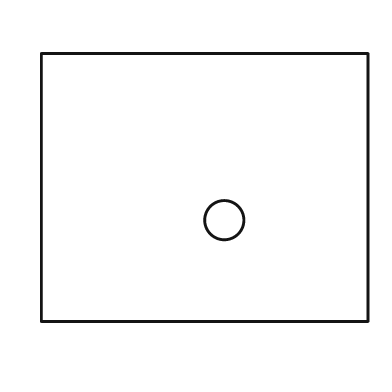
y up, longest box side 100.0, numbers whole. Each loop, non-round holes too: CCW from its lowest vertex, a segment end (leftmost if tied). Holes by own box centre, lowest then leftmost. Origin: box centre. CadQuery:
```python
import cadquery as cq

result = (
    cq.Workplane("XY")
    .moveTo(-50.0, -41.0)
    .lineTo(50.0, -41.0)
    .lineTo(50.0, 41.0)
    .lineTo(-50.0, 41.0)
    .close()
    .moveTo(6.0, -10.0)
    .circle(6.0)
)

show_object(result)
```